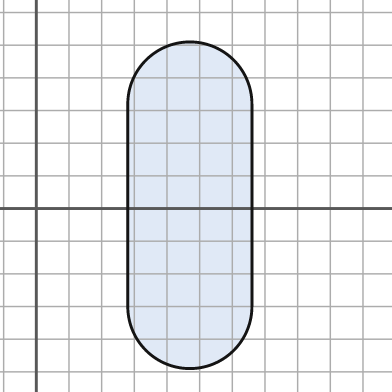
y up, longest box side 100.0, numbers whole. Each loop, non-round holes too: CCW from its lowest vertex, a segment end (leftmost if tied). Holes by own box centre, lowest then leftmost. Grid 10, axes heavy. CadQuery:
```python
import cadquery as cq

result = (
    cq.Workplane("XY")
    .moveTo(28.0, -30.0)
    .threePointArc((47.0, -49.0), (66.0, -30.0))
    .lineTo(66.0, 32.0)
    .threePointArc((47.0, 51.0), (28.0, 32.0))
    .close()
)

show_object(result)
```